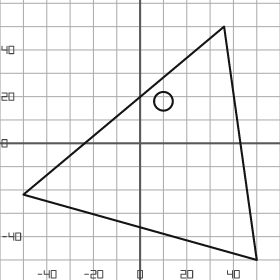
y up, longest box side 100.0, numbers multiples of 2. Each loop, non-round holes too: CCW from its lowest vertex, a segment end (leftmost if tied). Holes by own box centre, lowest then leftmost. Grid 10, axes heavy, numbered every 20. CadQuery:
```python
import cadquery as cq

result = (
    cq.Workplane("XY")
    .moveTo(50.0, -50.0)
    .lineTo(36.0, 50.0)
    .lineTo(-50.0, -22.0)
    .close()
    .moveTo(10.0, 18.0)
    .circle(4.0)
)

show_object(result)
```